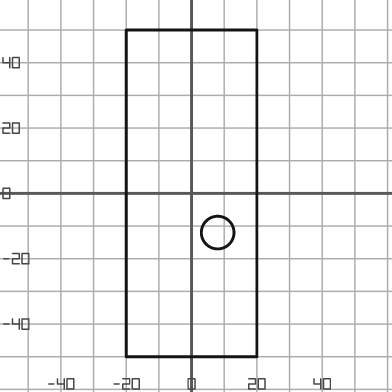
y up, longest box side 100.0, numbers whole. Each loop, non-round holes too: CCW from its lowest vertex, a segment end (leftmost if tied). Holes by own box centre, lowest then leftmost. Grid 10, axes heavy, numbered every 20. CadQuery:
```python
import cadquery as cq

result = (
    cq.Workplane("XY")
    .moveTo(-20.0, -50.0)
    .lineTo(20.0, -50.0)
    .lineTo(20.0, 50.0)
    .lineTo(-20.0, 50.0)
    .close()
    .moveTo(8.0, -12.0)
    .circle(5.0)
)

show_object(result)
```